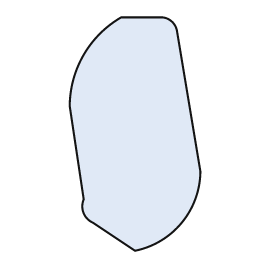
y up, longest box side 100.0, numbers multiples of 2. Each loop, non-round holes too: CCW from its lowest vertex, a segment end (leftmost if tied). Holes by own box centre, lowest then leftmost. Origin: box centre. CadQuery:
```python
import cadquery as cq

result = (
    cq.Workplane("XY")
    .moveTo(0.0, -50.0)
    .threePointArc((20.0, -38.0), (28.0, -16.0))
    .lineTo(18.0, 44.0)
    .threePointArc((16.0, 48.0), (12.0, 50.0))
    .lineTo(-6.0, 50.0)
    .threePointArc((-22.0, 34.0), (-28.0, 12.0))
    .lineTo(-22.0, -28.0)
    .threePointArc((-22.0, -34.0), (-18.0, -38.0))
    .close()
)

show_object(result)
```